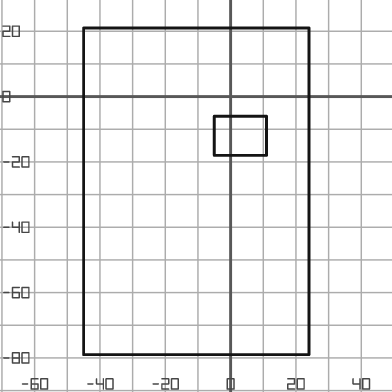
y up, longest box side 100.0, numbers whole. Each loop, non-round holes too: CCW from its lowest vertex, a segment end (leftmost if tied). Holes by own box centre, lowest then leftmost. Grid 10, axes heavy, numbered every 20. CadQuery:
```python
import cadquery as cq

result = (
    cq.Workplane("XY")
    .moveTo(-45.0, -79.0)
    .lineTo(24.0, -79.0)
    .lineTo(24.0, 21.0)
    .lineTo(-45.0, 21.0)
    .close()
    .moveTo(-5.0, -18.0)
    .lineTo(11.0, -18.0)
    .lineTo(11.0, -6.0)
    .lineTo(-5.0, -6.0)
    .close()
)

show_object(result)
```